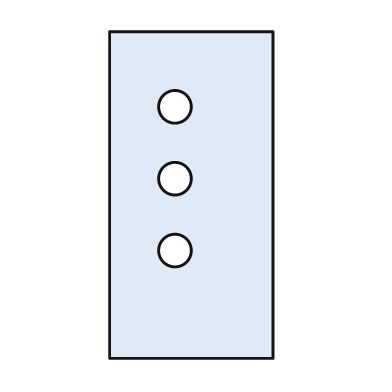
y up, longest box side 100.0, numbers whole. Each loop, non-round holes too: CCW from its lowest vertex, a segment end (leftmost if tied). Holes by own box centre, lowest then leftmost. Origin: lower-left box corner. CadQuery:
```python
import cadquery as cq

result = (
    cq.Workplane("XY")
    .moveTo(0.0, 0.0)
    .lineTo(50.0, 0.0)
    .lineTo(50.0, 100.0)
    .lineTo(0.0, 100.0)
    .close()
    .moveTo(20.0, 33.0)
    .circle(5.0)
    .moveTo(20.0, 55.0)
    .circle(5.0)
    .moveTo(20.0, 77.0)
    .circle(5.0)
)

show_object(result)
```